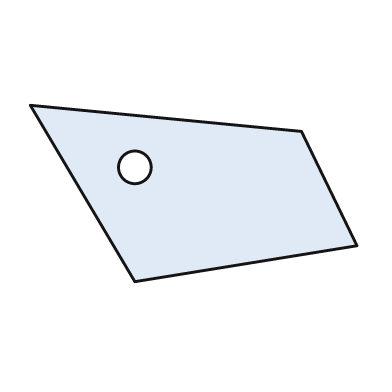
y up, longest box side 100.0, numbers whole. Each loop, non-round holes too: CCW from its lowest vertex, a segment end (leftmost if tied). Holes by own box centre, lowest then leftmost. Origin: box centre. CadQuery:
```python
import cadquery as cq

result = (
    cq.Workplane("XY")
    .moveTo(-18.0, -27.0)
    .lineTo(50.0, -16.0)
    .lineTo(33.0, 19.0)
    .lineTo(-50.0, 27.0)
    .close()
    .moveTo(-18.0, 8.0)
    .circle(5.0)
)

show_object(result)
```